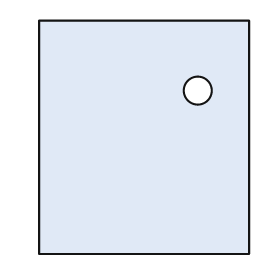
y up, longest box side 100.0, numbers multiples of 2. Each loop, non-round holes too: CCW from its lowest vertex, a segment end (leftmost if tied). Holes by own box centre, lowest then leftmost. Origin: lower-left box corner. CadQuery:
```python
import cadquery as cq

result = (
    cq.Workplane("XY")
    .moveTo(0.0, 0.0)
    .lineTo(90.0, 0.0)
    .lineTo(90.0, 100.0)
    .lineTo(0.0, 100.0)
    .close()
    .moveTo(68.0, 70.0)
    .circle(6.0)
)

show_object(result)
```